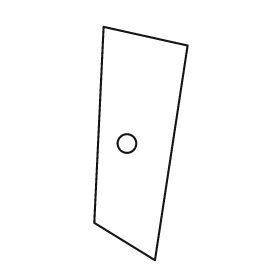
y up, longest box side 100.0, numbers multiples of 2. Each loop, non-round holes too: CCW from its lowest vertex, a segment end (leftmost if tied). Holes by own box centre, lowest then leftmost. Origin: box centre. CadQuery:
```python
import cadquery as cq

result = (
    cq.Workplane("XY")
    .moveTo(6.0, -50.0)
    .lineTo(20.0, 42.0)
    .lineTo(-16.0, 50.0)
    .lineTo(-20.0, -34.0)
    .close()
    .moveTo(-6.0, 0.0)
    .circle(4.0)
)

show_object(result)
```